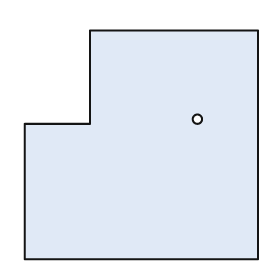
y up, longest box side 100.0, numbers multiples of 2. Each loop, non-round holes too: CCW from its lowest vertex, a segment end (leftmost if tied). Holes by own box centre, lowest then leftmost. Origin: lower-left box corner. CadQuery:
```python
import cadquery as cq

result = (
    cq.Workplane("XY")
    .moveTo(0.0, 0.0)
    .lineTo(100.0, 0.0)
    .lineTo(100.0, 98.0)
    .lineTo(28.0, 98.0)
    .lineTo(28.0, 58.0)
    .lineTo(0.0, 58.0)
    .close()
    .moveTo(74.0, 60.0)
    .circle(2.0)
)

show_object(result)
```